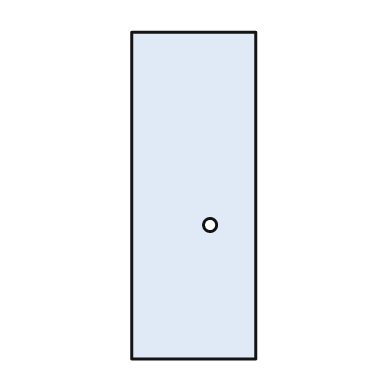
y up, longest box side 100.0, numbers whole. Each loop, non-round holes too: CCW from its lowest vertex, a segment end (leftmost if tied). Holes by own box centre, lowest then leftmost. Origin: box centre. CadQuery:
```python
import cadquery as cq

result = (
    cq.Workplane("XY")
    .moveTo(-19.0, -50.0)
    .lineTo(19.0, -50.0)
    .lineTo(19.0, 50.0)
    .lineTo(-19.0, 50.0)
    .close()
    .moveTo(5.0, -9.0)
    .circle(2.0)
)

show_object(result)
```